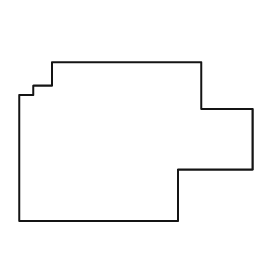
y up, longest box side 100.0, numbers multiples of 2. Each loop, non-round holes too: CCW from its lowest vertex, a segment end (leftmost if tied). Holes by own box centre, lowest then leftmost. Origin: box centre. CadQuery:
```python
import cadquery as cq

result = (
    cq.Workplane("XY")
    .moveTo(-50.0, -34.0)
    .lineTo(18.0, -34.0)
    .lineTo(18.0, -12.0)
    .lineTo(50.0, -12.0)
    .lineTo(50.0, 14.0)
    .lineTo(28.0, 14.0)
    .lineTo(28.0, 34.0)
    .lineTo(-36.0, 34.0)
    .lineTo(-36.0, 24.0)
    .lineTo(-44.0, 24.0)
    .lineTo(-44.0, 20.0)
    .lineTo(-50.0, 20.0)
    .close()
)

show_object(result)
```